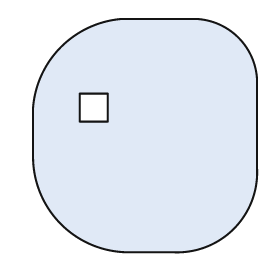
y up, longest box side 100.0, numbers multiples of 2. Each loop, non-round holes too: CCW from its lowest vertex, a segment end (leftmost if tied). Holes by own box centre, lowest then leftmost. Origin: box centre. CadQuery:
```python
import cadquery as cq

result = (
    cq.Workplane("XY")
    .moveTo(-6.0, -50.0)
    .lineTo(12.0, -50.0)
    .threePointArc((38.0, -40.0), (48.0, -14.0))
    .lineTo(48.0, 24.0)
    .threePointArc((40.0, 42.0), (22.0, 50.0))
    .lineTo(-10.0, 50.0)
    .threePointArc((-36.0, 38.0), (-48.0, 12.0))
    .lineTo(-48.0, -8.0)
    .threePointArc((-36.0, -38.0), (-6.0, -50.0))
    .close()
    .moveTo(-28.0, 6.0)
    .lineTo(-16.0, 6.0)
    .lineTo(-16.0, 18.0)
    .lineTo(-28.0, 18.0)
    .close()
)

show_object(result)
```